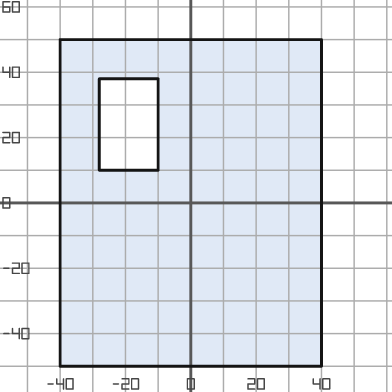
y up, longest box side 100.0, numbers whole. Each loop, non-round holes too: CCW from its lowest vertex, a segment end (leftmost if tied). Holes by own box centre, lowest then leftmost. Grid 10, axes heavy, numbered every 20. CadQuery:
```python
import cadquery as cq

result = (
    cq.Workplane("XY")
    .moveTo(-40.0, -50.0)
    .lineTo(40.0, -50.0)
    .lineTo(40.0, 50.0)
    .lineTo(-40.0, 50.0)
    .close()
    .moveTo(-28.0, 10.0)
    .lineTo(-10.0, 10.0)
    .lineTo(-10.0, 38.0)
    .lineTo(-28.0, 38.0)
    .close()
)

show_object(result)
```